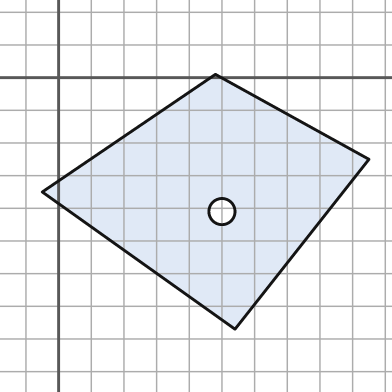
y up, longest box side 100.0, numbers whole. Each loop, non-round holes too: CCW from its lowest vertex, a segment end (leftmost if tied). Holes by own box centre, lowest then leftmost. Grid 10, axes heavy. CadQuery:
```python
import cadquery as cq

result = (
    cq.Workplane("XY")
    .moveTo(54.0, -77.0)
    .lineTo(95.0, -25.0)
    .lineTo(48.0, 1.0)
    .lineTo(-5.0, -35.0)
    .close()
    .moveTo(50.0, -41.0)
    .circle(4.0)
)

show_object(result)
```